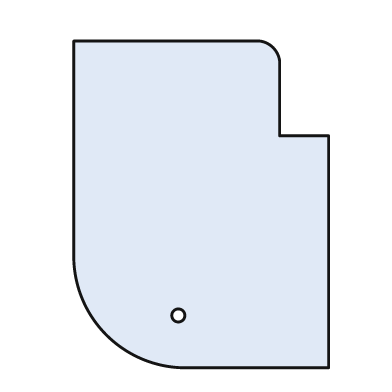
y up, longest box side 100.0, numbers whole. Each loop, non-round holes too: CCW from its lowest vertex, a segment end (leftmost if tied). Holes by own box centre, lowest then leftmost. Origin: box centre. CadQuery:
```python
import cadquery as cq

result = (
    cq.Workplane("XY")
    .moveTo(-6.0, -50.0)
    .lineTo(39.0, -50.0)
    .lineTo(39.0, 21.0)
    .lineTo(24.0, 21.0)
    .lineTo(24.0, 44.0)
    .threePointArc((22.0, 48.0), (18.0, 50.0))
    .lineTo(-39.0, 50.0)
    .lineTo(-39.0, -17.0)
    .threePointArc((-29.0, -40.0), (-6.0, -50.0))
    .close()
    .moveTo(-7.0, -34.0)
    .circle(2.0)
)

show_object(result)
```